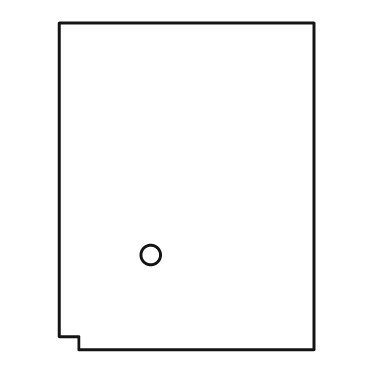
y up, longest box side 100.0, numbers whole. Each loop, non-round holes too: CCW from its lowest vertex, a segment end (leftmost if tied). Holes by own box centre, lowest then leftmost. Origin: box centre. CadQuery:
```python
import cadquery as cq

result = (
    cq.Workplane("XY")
    .moveTo(-33.0, -50.0)
    .lineTo(39.0, -50.0)
    .lineTo(39.0, 50.0)
    .lineTo(-39.0, 50.0)
    .lineTo(-39.0, -46.0)
    .lineTo(-33.0, -46.0)
    .close()
    .moveTo(-11.0, -21.0)
    .circle(3.0)
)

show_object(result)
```